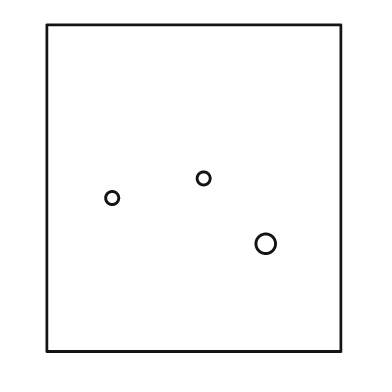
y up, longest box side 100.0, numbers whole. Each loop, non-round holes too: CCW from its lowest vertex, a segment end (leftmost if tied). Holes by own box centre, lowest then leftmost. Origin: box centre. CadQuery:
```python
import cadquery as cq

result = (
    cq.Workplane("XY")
    .moveTo(-45.0, -50.0)
    .lineTo(45.0, -50.0)
    .lineTo(45.0, 50.0)
    .lineTo(-45.0, 50.0)
    .close()
    .moveTo(22.0, -17.0)
    .circle(3.0)
    .moveTo(-25.0, -3.0)
    .circle(2.0)
    .moveTo(3.0, 3.0)
    .circle(2.0)
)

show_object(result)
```